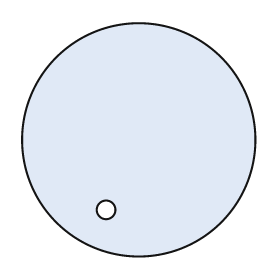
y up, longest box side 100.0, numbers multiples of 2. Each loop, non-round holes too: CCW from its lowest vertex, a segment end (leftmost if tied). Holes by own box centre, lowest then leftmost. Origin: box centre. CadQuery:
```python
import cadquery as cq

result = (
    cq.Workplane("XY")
    .moveTo(0.0, 0.0)
    .circle(50.0)
    .moveTo(-14.0, -30.0)
    .circle(4.0)
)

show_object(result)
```